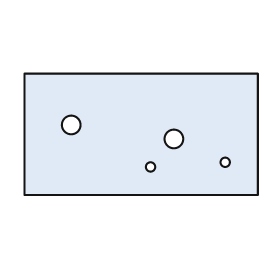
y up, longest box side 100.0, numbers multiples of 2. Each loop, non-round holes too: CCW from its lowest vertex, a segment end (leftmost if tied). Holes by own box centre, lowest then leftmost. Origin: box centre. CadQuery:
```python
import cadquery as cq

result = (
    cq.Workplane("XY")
    .moveTo(-50.0, -26.0)
    .lineTo(50.0, -26.0)
    .lineTo(50.0, 26.0)
    .lineTo(-50.0, 26.0)
    .close()
    .moveTo(4.0, -14.0)
    .circle(2.0)
    .moveTo(36.0, -12.0)
    .circle(2.0)
    .moveTo(14.0, -2.0)
    .circle(4.0)
    .moveTo(-30.0, 4.0)
    .circle(4.0)
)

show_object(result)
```